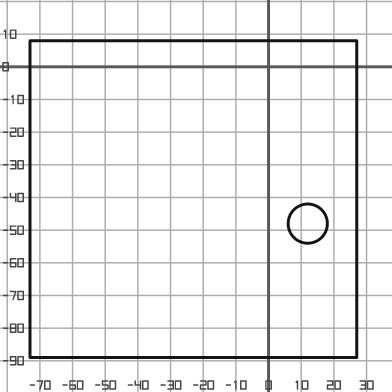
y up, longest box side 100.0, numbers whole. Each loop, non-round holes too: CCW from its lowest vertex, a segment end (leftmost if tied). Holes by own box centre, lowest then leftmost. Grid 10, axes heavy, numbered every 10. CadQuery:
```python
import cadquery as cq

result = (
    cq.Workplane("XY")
    .moveTo(-73.0, -89.0)
    .lineTo(27.0, -89.0)
    .lineTo(27.0, 8.0)
    .lineTo(-73.0, 8.0)
    .close()
    .moveTo(12.0, -48.0)
    .circle(6.0)
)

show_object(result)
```